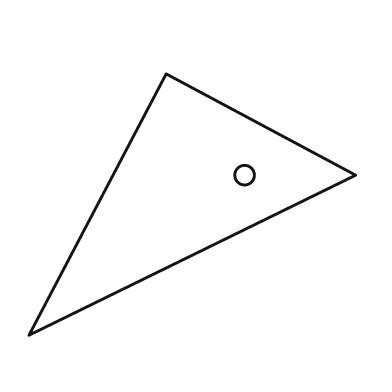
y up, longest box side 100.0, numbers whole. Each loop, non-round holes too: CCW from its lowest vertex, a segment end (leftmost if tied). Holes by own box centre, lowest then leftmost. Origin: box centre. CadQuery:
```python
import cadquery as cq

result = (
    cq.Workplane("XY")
    .moveTo(-50.0, -40.0)
    .lineTo(50.0, 9.0)
    .lineTo(-8.0, 40.0)
    .close()
    .moveTo(16.0, 9.0)
    .circle(3.0)
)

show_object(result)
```